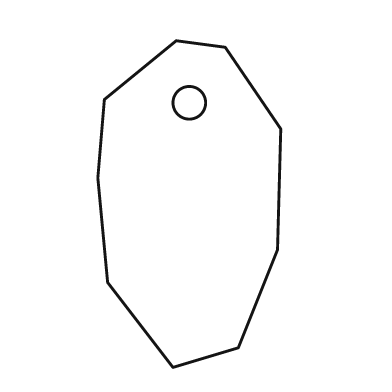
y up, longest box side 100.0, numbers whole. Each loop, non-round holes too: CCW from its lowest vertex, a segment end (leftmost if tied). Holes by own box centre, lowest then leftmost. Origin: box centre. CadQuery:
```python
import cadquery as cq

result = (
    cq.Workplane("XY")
    .moveTo(-5.0, -50.0)
    .lineTo(15.0, -44.0)
    .lineTo(27.0, -14.0)
    .lineTo(28.0, 23.0)
    .lineTo(11.0, 48.0)
    .lineTo(-4.0, 50.0)
    .lineTo(-26.0, 32.0)
    .lineTo(-28.0, 8.0)
    .lineTo(-25.0, -24.0)
    .close()
    .moveTo(0.0, 31.0)
    .circle(5.0)
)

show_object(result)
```